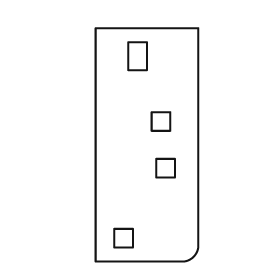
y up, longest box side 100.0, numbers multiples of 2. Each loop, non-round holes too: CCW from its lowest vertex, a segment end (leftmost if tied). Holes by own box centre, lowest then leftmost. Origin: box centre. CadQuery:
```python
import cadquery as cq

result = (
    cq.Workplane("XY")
    .moveTo(-22.0, -50.0)
    .lineTo(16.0, -50.0)
    .threePointArc((20.0, -48.0), (22.0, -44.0))
    .lineTo(22.0, 50.0)
    .lineTo(-22.0, 50.0)
    .close()
    .moveTo(-14.0, -44.0)
    .lineTo(-6.0, -44.0)
    .lineTo(-6.0, -36.0)
    .lineTo(-14.0, -36.0)
    .close()
    .moveTo(4.0, -14.0)
    .lineTo(12.0, -14.0)
    .lineTo(12.0, -6.0)
    .lineTo(4.0, -6.0)
    .close()
    .moveTo(2.0, 6.0)
    .lineTo(10.0, 6.0)
    .lineTo(10.0, 14.0)
    .lineTo(2.0, 14.0)
    .close()
    .moveTo(-8.0, 32.0)
    .lineTo(0.0, 32.0)
    .lineTo(0.0, 44.0)
    .lineTo(-8.0, 44.0)
    .close()
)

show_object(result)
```